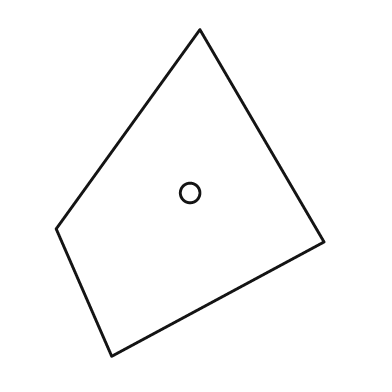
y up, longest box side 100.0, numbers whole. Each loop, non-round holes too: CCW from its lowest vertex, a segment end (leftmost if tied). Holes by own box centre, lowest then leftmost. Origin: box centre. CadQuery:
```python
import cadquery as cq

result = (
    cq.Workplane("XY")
    .moveTo(-24.0, -50.0)
    .lineTo(41.0, -15.0)
    .lineTo(3.0, 50.0)
    .lineTo(-41.0, -11.0)
    .close()
    .moveTo(0.0, 0.0)
    .circle(3.0)
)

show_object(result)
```